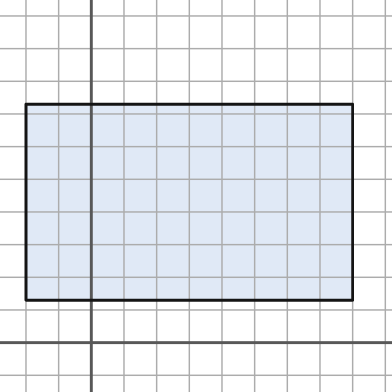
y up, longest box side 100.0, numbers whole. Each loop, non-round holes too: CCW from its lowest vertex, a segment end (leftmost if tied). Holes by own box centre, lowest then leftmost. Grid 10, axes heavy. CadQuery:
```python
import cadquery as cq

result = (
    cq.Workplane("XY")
    .moveTo(-20.0, 13.0)
    .lineTo(80.0, 13.0)
    .lineTo(80.0, 73.0)
    .lineTo(-20.0, 73.0)
    .close()
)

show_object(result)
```